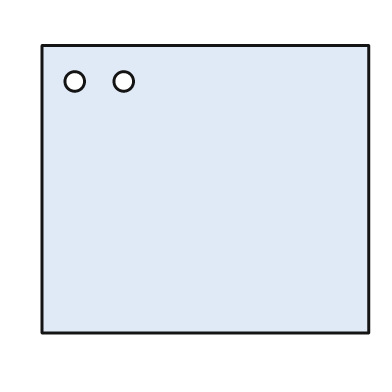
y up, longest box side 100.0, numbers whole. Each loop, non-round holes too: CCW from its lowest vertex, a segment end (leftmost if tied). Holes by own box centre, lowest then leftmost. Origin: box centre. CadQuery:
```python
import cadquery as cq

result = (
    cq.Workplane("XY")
    .moveTo(-50.0, -44.0)
    .lineTo(50.0, -44.0)
    .lineTo(50.0, 44.0)
    .lineTo(-50.0, 44.0)
    .close()
    .moveTo(-40.0, 33.0)
    .circle(3.0)
    .moveTo(-25.0, 33.0)
    .circle(3.0)
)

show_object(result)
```